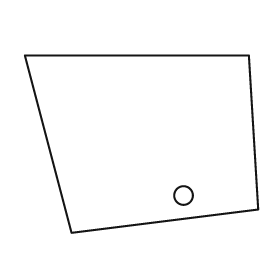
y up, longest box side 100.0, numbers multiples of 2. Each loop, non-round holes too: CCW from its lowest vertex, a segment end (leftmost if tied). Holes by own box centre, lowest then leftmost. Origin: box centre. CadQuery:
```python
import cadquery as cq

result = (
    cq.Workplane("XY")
    .moveTo(-30.0, -38.0)
    .lineTo(50.0, -28.0)
    .lineTo(46.0, 38.0)
    .lineTo(-50.0, 38.0)
    .close()
    .moveTo(18.0, -22.0)
    .circle(4.0)
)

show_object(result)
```